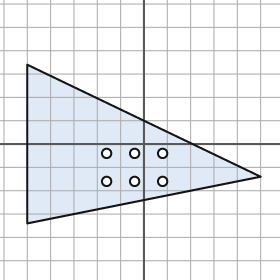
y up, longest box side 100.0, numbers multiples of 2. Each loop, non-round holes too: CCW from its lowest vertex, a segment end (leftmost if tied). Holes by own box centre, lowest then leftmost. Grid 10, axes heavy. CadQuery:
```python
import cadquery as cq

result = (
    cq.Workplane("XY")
    .moveTo(-50.0, -34.0)
    .lineTo(50.0, -14.0)
    .lineTo(-50.0, 34.0)
    .close()
    .moveTo(-16.0, -16.0)
    .circle(2.0)
    .moveTo(-4.0, -16.0)
    .circle(2.0)
    .moveTo(8.0, -16.0)
    .circle(2.0)
    .moveTo(-16.0, -4.0)
    .circle(2.0)
    .moveTo(-4.0, -4.0)
    .circle(2.0)
    .moveTo(8.0, -4.0)
    .circle(2.0)
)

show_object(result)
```